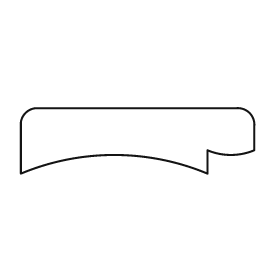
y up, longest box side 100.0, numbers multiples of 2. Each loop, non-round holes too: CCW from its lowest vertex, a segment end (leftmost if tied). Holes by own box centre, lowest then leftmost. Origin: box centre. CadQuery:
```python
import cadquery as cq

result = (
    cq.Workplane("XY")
    .moveTo(-50.0, -14.0)
    .threePointArc((-10.0, -6.0), (30.0, -14.0))
    .lineTo(30.0, -4.0)
    .threePointArc((40.0, -6.0), (50.0, -4.0))
    .lineTo(50.0, 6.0)
    .threePointArc((48.0, 12.0), (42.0, 14.0))
    .lineTo(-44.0, 14.0)
    .threePointArc((-48.0, 12.0), (-50.0, 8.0))
    .close()
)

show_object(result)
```